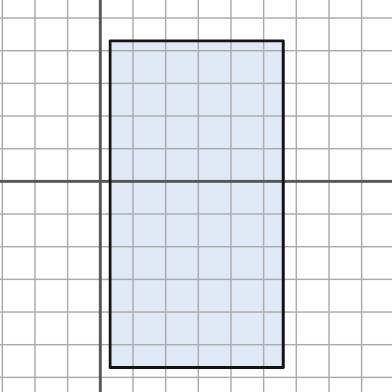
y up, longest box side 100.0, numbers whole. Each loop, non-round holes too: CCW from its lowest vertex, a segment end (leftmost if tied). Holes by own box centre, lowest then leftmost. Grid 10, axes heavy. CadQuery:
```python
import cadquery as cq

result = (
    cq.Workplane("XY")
    .moveTo(3.0, -57.0)
    .lineTo(56.0, -57.0)
    .lineTo(56.0, 43.0)
    .lineTo(3.0, 43.0)
    .close()
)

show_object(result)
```